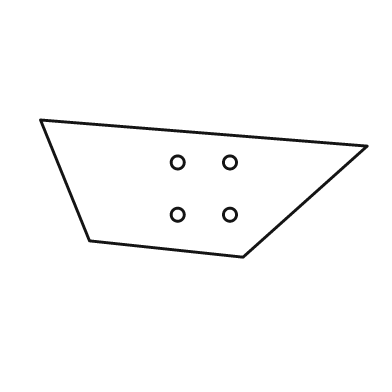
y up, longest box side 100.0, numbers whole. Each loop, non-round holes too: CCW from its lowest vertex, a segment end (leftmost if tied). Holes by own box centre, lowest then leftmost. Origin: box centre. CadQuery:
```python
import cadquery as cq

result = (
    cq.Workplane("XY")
    .moveTo(12.0, -21.0)
    .lineTo(50.0, 13.0)
    .lineTo(-50.0, 21.0)
    .lineTo(-35.0, -16.0)
    .close()
    .moveTo(-8.0, -8.0)
    .circle(2.0)
    .moveTo(8.0, -8.0)
    .circle(2.0)
    .moveTo(-8.0, 8.0)
    .circle(2.0)
    .moveTo(8.0, 8.0)
    .circle(2.0)
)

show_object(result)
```